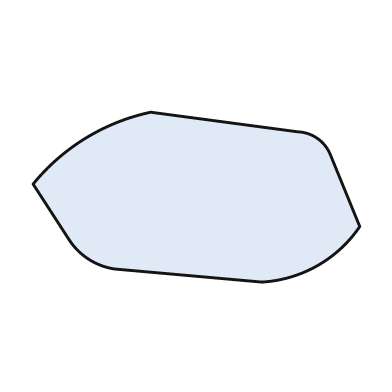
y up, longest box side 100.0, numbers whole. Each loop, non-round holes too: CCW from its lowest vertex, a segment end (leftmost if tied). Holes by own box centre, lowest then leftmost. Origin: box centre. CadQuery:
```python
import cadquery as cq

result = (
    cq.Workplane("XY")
    .moveTo(20.0, -26.0)
    .threePointArc((37.0, -21.0), (50.0, -9.0))
    .lineTo(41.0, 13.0)
    .threePointArc((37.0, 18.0), (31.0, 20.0))
    .lineTo(-14.0, 26.0)
    .threePointArc((-34.0, 18.0), (-50.0, 4.0))
    .lineTo(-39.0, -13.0)
    .threePointArc((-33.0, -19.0), (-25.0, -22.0))
    .close()
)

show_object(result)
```